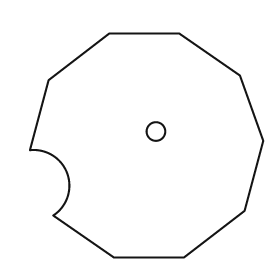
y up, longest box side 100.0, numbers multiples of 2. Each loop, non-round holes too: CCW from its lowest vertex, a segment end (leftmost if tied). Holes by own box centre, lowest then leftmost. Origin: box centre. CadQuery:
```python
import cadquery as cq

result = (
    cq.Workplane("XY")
    .moveTo(-14.0, -48.0)
    .lineTo(16.0, -48.0)
    .lineTo(42.0, -28.0)
    .lineTo(50.0, 2.0)
    .lineTo(40.0, 30.0)
    .lineTo(14.0, 48.0)
    .lineTo(-16.0, 48.0)
    .lineTo(-42.0, 28.0)
    .lineTo(-50.0, -2.0)
    .threePointArc((-34.0, -12.0), (-40.0, -30.0))
    .close()
    .moveTo(4.0, 6.0)
    .circle(4.0)
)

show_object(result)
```